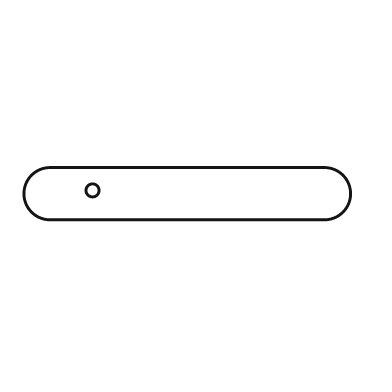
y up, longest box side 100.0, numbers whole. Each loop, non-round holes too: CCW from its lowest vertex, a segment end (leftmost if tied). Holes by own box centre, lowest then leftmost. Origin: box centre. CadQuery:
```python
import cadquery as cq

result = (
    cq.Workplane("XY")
    .moveTo(-42.0, -8.0)
    .lineTo(42.0, -8.0)
    .threePointArc((50.0, 0.0), (42.0, 8.0))
    .lineTo(-42.0, 8.0)
    .threePointArc((-50.0, 0.0), (-42.0, -8.0))
    .close()
    .moveTo(-29.0, 1.0)
    .circle(2.0)
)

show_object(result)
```